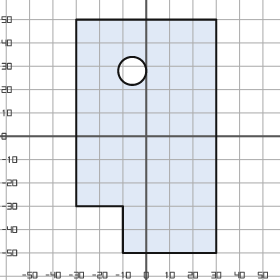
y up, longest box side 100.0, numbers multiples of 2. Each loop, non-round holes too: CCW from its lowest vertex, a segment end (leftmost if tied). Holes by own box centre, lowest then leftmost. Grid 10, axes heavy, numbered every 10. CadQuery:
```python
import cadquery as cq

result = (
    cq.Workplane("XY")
    .moveTo(-10.0, -50.0)
    .lineTo(30.0, -50.0)
    .lineTo(30.0, 50.0)
    .lineTo(-30.0, 50.0)
    .lineTo(-30.0, -30.0)
    .lineTo(-10.0, -30.0)
    .close()
    .moveTo(-6.0, 28.0)
    .circle(6.0)
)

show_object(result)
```